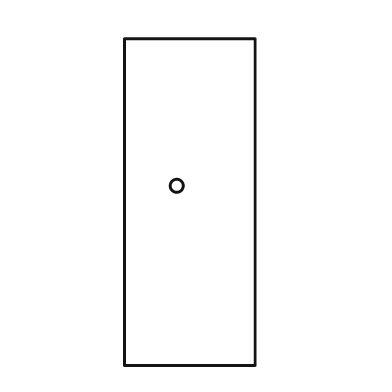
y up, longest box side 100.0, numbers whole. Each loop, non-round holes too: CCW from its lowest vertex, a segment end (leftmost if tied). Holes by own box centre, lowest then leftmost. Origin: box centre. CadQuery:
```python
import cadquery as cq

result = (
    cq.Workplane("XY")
    .moveTo(-20.0, -50.0)
    .lineTo(20.0, -50.0)
    .lineTo(20.0, 50.0)
    .lineTo(-20.0, 50.0)
    .close()
    .moveTo(-4.0, 5.0)
    .circle(2.0)
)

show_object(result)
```